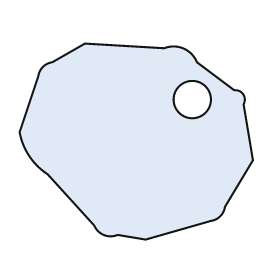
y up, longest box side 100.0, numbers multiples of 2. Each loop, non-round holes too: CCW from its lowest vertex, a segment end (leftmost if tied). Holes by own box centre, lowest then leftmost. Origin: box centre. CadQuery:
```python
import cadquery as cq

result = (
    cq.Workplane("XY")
    .moveTo(4.0, -42.0)
    .lineTo(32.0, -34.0)
    .threePointArc((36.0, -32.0), (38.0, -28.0))
    .lineTo(50.0, -8.0)
    .lineTo(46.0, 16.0)
    .threePointArc((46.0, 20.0), (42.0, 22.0))
    .lineTo(26.0, 34.0)
    .threePointArc((20.0, 40.0), (12.0, 40.0))
    .lineTo(-22.0, 42.0)
    .lineTo(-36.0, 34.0)
    .threePointArc((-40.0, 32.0), (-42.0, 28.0))
    .lineTo(-50.0, 4.0)
    .threePointArc((-46.0, -6.0), (-38.0, -14.0))
    .lineTo(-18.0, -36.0)
    .threePointArc((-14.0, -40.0), (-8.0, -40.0))
    .close()
    .moveTo(24.0, 18.0)
    .circle(8.0)
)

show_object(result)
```